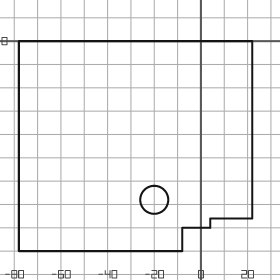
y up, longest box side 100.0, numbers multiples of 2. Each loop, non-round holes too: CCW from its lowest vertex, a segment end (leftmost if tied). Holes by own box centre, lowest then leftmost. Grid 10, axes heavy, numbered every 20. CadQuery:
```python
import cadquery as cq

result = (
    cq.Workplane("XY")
    .moveTo(-78.0, -90.0)
    .lineTo(-8.0, -90.0)
    .lineTo(-8.0, -80.0)
    .lineTo(4.0, -80.0)
    .lineTo(4.0, -76.0)
    .lineTo(22.0, -76.0)
    .lineTo(22.0, 0.0)
    .lineTo(-78.0, 0.0)
    .close()
    .moveTo(-20.0, -68.0)
    .circle(6.0)
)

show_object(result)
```